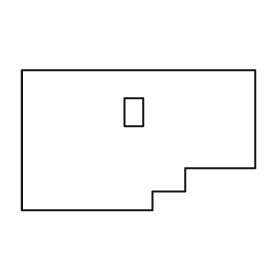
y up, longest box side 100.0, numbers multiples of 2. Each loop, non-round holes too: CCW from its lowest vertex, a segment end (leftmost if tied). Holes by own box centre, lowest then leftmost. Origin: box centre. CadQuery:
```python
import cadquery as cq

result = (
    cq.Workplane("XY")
    .moveTo(-50.0, -30.0)
    .lineTo(6.0, -30.0)
    .lineTo(6.0, -22.0)
    .lineTo(20.0, -22.0)
    .lineTo(20.0, -12.0)
    .lineTo(50.0, -12.0)
    .lineTo(50.0, 30.0)
    .lineTo(-50.0, 30.0)
    .close()
    .moveTo(-6.0, 6.0)
    .lineTo(2.0, 6.0)
    .lineTo(2.0, 18.0)
    .lineTo(-6.0, 18.0)
    .close()
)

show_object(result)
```